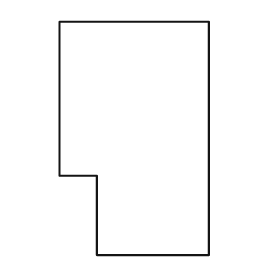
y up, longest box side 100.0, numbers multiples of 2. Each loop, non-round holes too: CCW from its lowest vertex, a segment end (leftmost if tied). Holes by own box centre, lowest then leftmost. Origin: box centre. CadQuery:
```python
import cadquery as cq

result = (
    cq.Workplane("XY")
    .moveTo(-16.0, -50.0)
    .lineTo(32.0, -50.0)
    .lineTo(32.0, 50.0)
    .lineTo(-32.0, 50.0)
    .lineTo(-32.0, -16.0)
    .lineTo(-16.0, -16.0)
    .close()
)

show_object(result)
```